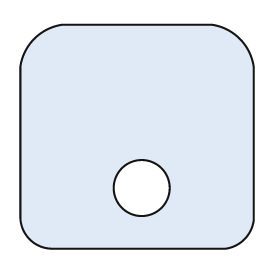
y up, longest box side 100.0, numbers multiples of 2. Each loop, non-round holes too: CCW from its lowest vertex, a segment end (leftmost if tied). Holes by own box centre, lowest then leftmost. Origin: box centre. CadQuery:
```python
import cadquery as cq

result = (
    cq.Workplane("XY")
    .moveTo(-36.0, -48.0)
    .lineTo(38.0, -48.0)
    .threePointArc((46.0, -44.0), (50.0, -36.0))
    .lineTo(50.0, 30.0)
    .threePointArc((44.0, 42.0), (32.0, 48.0))
    .lineTo(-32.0, 48.0)
    .threePointArc((-44.0, 42.0), (-50.0, 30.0))
    .lineTo(-50.0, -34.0)
    .threePointArc((-46.0, -44.0), (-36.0, -48.0))
    .close()
    .moveTo(2.0, -22.0)
    .circle(12.0)
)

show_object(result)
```